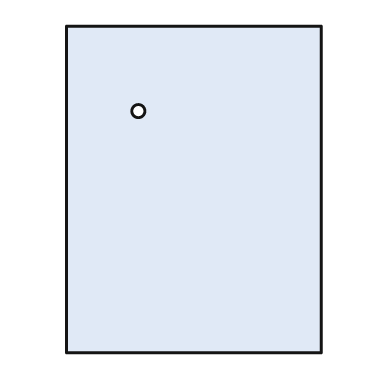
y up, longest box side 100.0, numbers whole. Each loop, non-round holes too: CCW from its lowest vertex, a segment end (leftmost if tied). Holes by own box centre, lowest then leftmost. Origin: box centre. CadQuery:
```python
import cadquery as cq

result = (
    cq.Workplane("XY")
    .moveTo(-39.0, -50.0)
    .lineTo(39.0, -50.0)
    .lineTo(39.0, 50.0)
    .lineTo(-39.0, 50.0)
    .close()
    .moveTo(-17.0, 24.0)
    .circle(2.0)
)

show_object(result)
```